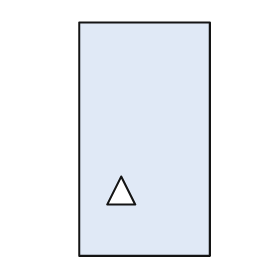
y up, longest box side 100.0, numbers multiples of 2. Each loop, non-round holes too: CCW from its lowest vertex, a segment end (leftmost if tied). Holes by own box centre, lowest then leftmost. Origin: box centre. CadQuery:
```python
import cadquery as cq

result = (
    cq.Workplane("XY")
    .moveTo(-28.0, -50.0)
    .lineTo(28.0, -50.0)
    .lineTo(28.0, 50.0)
    .lineTo(-28.0, 50.0)
    .close()
    .moveTo(-16.0, -28.0)
    .lineTo(-4.0, -28.0)
    .lineTo(-10.0, -16.0)
    .close()
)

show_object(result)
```